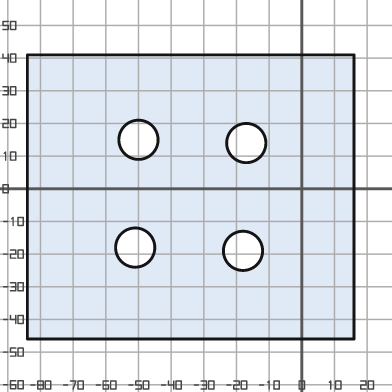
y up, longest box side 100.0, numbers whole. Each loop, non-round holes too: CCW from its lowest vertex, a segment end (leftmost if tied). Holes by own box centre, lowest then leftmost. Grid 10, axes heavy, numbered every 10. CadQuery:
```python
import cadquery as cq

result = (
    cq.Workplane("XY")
    .moveTo(-84.0, -46.0)
    .lineTo(16.0, -46.0)
    .lineTo(16.0, 41.0)
    .lineTo(-84.0, 41.0)
    .close()
    .moveTo(-18.0, -19.0)
    .circle(6.0)
    .moveTo(-51.0, -18.0)
    .circle(6.0)
    .moveTo(-17.0, 14.0)
    .circle(6.0)
    .moveTo(-50.0, 15.0)
    .circle(6.0)
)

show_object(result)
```